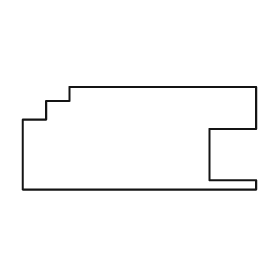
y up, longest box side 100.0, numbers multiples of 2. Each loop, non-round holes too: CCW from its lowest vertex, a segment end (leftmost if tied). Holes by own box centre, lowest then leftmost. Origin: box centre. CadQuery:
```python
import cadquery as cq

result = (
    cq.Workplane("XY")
    .moveTo(-50.0, -22.0)
    .lineTo(50.0, -22.0)
    .lineTo(50.0, -18.0)
    .lineTo(30.0, -18.0)
    .lineTo(30.0, 4.0)
    .lineTo(50.0, 4.0)
    .lineTo(50.0, 22.0)
    .lineTo(-30.0, 22.0)
    .lineTo(-30.0, 16.0)
    .lineTo(-40.0, 16.0)
    .lineTo(-40.0, 8.0)
    .lineTo(-50.0, 8.0)
    .close()
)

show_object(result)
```